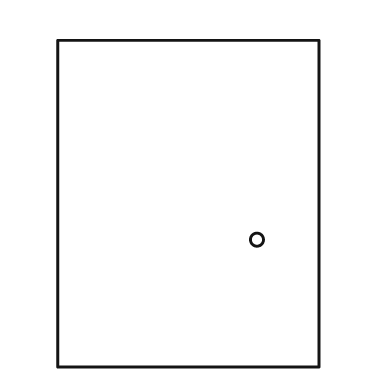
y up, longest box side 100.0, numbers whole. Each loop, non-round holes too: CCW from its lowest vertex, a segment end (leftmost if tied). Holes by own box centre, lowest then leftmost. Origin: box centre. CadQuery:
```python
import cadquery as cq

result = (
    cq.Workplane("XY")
    .moveTo(-40.0, -50.0)
    .lineTo(40.0, -50.0)
    .lineTo(40.0, 50.0)
    .lineTo(-40.0, 50.0)
    .close()
    .moveTo(21.0, -11.0)
    .circle(2.0)
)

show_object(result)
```